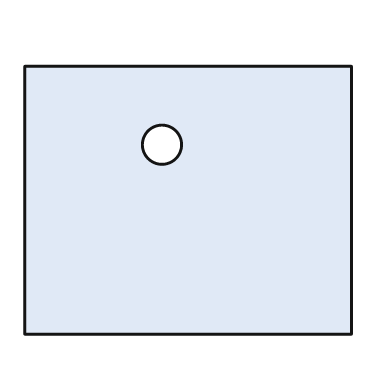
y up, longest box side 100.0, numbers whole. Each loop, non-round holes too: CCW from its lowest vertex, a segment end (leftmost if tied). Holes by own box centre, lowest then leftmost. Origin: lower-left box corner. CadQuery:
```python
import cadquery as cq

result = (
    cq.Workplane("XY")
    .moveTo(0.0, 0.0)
    .lineTo(100.0, 0.0)
    .lineTo(100.0, 82.0)
    .lineTo(0.0, 82.0)
    .close()
    .moveTo(42.0, 58.0)
    .circle(6.0)
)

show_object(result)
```